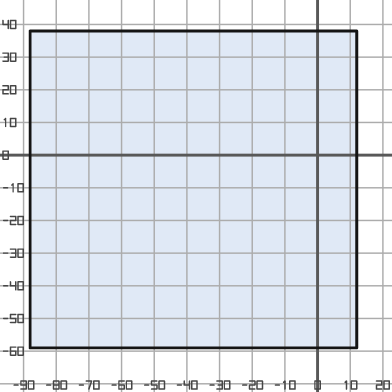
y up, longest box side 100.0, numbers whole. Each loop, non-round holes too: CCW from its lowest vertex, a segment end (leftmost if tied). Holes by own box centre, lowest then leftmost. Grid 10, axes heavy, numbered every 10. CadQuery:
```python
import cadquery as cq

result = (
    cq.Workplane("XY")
    .moveTo(-88.0, -59.0)
    .lineTo(12.0, -59.0)
    .lineTo(12.0, 38.0)
    .lineTo(-88.0, 38.0)
    .close()
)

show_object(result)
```